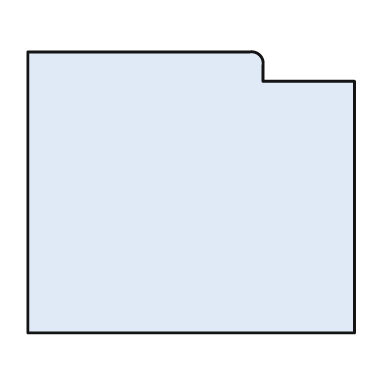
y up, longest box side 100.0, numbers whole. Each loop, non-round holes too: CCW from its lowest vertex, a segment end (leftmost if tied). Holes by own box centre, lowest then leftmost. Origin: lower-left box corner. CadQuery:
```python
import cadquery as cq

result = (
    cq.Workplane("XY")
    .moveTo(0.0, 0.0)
    .lineTo(100.0, 0.0)
    .lineTo(100.0, 77.0)
    .lineTo(72.0, 77.0)
    .lineTo(72.0, 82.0)
    .threePointArc((71.0, 85.0), (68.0, 86.0))
    .lineTo(0.0, 86.0)
    .close()
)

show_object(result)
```